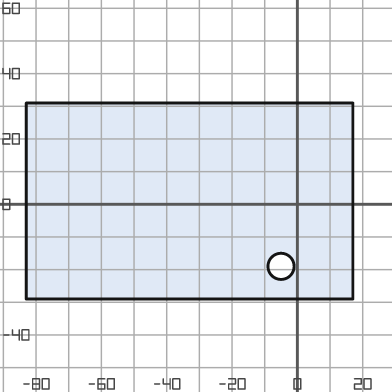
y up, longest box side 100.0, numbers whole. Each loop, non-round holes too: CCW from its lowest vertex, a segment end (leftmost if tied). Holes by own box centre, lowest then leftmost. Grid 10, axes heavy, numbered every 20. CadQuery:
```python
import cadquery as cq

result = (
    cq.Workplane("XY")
    .moveTo(-83.0, -29.0)
    .lineTo(17.0, -29.0)
    .lineTo(17.0, 31.0)
    .lineTo(-83.0, 31.0)
    .close()
    .moveTo(-5.0, -19.0)
    .circle(4.0)
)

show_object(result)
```